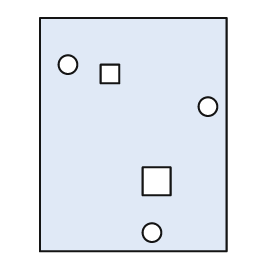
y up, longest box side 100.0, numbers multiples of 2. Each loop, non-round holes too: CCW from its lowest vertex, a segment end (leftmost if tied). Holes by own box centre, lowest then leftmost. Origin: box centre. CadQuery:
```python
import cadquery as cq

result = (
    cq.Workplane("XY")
    .moveTo(-40.0, -50.0)
    .lineTo(40.0, -50.0)
    .lineTo(40.0, 50.0)
    .lineTo(-40.0, 50.0)
    .close()
    .moveTo(8.0, -42.0)
    .circle(4.0)
    .moveTo(4.0, -26.0)
    .lineTo(16.0, -26.0)
    .lineTo(16.0, -14.0)
    .lineTo(4.0, -14.0)
    .close()
    .moveTo(32.0, 12.0)
    .circle(4.0)
    .moveTo(-14.0, 22.0)
    .lineTo(-6.0, 22.0)
    .lineTo(-6.0, 30.0)
    .lineTo(-14.0, 30.0)
    .close()
    .moveTo(-28.0, 30.0)
    .circle(4.0)
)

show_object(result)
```